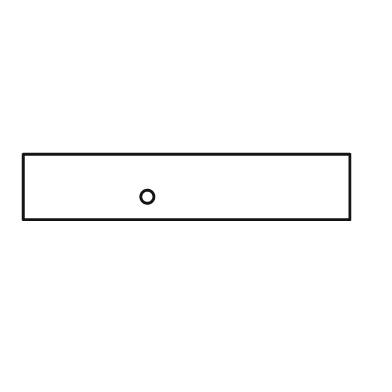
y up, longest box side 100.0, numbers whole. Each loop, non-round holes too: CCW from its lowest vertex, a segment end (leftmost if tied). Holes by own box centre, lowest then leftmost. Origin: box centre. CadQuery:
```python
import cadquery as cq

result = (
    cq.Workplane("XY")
    .moveTo(-50.0, -10.0)
    .lineTo(50.0, -10.0)
    .lineTo(50.0, 10.0)
    .lineTo(-50.0, 10.0)
    .close()
    .moveTo(-12.0, -3.0)
    .circle(2.0)
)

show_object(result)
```